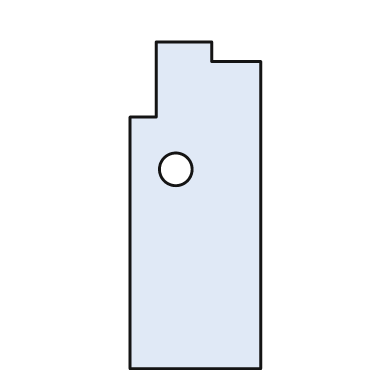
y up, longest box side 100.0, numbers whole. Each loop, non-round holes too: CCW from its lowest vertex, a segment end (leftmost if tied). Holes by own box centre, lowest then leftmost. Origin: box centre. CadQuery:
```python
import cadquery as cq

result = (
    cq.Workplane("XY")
    .moveTo(-20.0, -50.0)
    .lineTo(20.0, -50.0)
    .lineTo(20.0, 44.0)
    .lineTo(5.0, 44.0)
    .lineTo(5.0, 50.0)
    .lineTo(-12.0, 50.0)
    .lineTo(-12.0, 27.0)
    .lineTo(-20.0, 27.0)
    .close()
    .moveTo(-6.0, 11.0)
    .circle(5.0)
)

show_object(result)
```